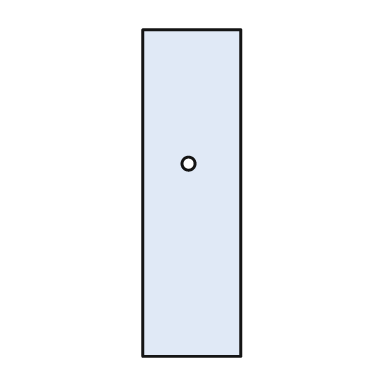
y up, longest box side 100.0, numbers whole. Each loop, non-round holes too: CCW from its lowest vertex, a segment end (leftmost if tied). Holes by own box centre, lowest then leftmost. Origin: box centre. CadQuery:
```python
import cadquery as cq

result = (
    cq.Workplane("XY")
    .moveTo(-15.0, -50.0)
    .lineTo(15.0, -50.0)
    .lineTo(15.0, 50.0)
    .lineTo(-15.0, 50.0)
    .close()
    .moveTo(-1.0, 9.0)
    .circle(2.0)
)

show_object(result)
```